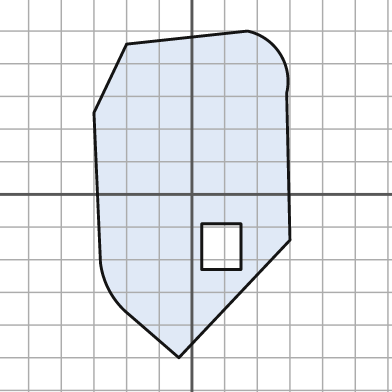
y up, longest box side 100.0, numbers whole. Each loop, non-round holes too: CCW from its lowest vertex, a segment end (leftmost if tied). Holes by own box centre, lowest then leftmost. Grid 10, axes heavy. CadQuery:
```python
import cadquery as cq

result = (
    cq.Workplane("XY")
    .moveTo(-4.0, -50.0)
    .lineTo(30.0, -14.0)
    .lineTo(29.0, 31.0)
    .threePointArc((27.0, 43.0), (17.0, 50.0))
    .lineTo(-20.0, 46.0)
    .lineTo(-30.0, 25.0)
    .lineTo(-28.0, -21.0)
    .threePointArc((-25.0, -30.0), (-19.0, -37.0))
    .close()
    .moveTo(3.0, -23.0)
    .lineTo(15.0, -23.0)
    .lineTo(15.0, -9.0)
    .lineTo(3.0, -9.0)
    .close()
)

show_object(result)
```